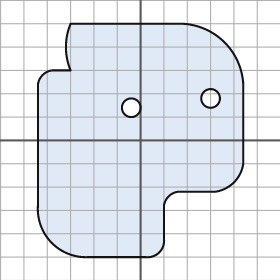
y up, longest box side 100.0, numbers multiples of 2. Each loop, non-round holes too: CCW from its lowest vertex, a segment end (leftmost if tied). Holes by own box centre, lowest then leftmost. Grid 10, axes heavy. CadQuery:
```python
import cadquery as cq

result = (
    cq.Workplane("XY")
    .moveTo(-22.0, -50.0)
    .lineTo(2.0, -50.0)
    .threePointArc((8.0, -48.0), (10.0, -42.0))
    .lineTo(10.0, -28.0)
    .threePointArc((12.0, -24.0), (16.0, -22.0))
    .lineTo(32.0, -22.0)
    .threePointArc((40.0, -18.0), (44.0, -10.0))
    .lineTo(44.0, 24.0)
    .threePointArc((36.0, 42.0), (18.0, 50.0))
    .lineTo(-30.0, 50.0)
    .threePointArc((-32.0, 40.0), (-30.0, 30.0))
    .lineTo(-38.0, 30.0)
    .threePointArc((-42.0, 28.0), (-44.0, 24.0))
    .lineTo(-44.0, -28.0)
    .threePointArc((-38.0, -44.0), (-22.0, -50.0))
    .close()
    .moveTo(-4.0, 14.0)
    .circle(4.0)
    .moveTo(30.0, 18.0)
    .circle(4.0)
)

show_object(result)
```